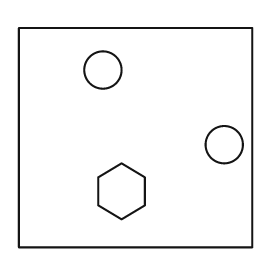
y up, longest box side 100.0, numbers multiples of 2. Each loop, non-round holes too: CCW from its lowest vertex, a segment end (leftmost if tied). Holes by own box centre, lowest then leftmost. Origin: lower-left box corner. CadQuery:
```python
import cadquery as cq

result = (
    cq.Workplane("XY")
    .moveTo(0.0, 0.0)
    .lineTo(100.0, 0.0)
    .lineTo(100.0, 94.0)
    .lineTo(0.0, 94.0)
    .close()
    .moveTo(44.0, 12.0)
    .lineTo(54.0, 18.0)
    .lineTo(54.0, 30.0)
    .lineTo(44.0, 36.0)
    .lineTo(34.0, 30.0)
    .lineTo(34.0, 18.0)
    .close()
    .moveTo(88.0, 44.0)
    .circle(8.0)
    .moveTo(36.0, 76.0)
    .circle(8.0)
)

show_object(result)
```